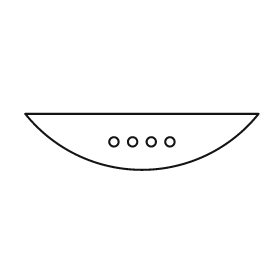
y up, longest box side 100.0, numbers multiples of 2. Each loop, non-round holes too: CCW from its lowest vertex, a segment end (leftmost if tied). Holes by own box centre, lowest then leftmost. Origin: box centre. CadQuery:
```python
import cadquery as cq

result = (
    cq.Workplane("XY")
    .moveTo(-50.0, 12.0)
    .threePointArc((0.0, -12.0), (50.0, 12.0))
    .close()
    .moveTo(-12.0, 0.0)
    .circle(2.0)
    .moveTo(-4.0, 0.0)
    .circle(2.0)
    .moveTo(4.0, 0.0)
    .circle(2.0)
    .moveTo(12.0, 0.0)
    .circle(2.0)
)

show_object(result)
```